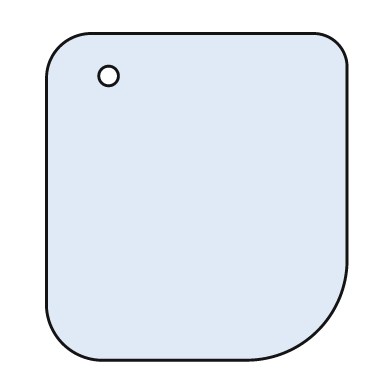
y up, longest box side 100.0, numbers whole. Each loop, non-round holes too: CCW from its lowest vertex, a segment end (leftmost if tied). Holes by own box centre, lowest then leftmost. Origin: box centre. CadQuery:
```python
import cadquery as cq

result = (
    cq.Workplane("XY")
    .moveTo(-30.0, -50.0)
    .lineTo(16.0, -50.0)
    .threePointArc((37.0, -41.0), (46.0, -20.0))
    .lineTo(46.0, 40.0)
    .threePointArc((43.0, 47.0), (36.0, 50.0))
    .lineTo(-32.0, 50.0)
    .threePointArc((-42.0, 46.0), (-46.0, 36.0))
    .lineTo(-46.0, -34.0)
    .threePointArc((-41.0, -45.0), (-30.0, -50.0))
    .close()
    .moveTo(-27.0, 37.0)
    .circle(3.0)
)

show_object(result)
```